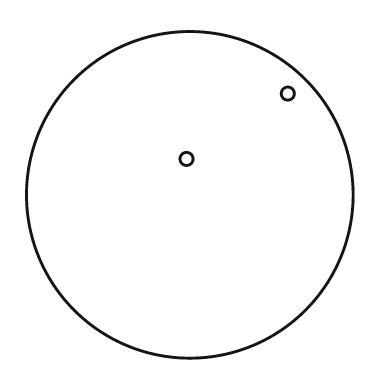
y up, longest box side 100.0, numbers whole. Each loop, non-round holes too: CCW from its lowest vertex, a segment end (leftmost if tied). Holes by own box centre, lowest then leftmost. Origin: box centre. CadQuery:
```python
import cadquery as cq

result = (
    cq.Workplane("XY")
    .moveTo(0.0, 0.0)
    .circle(50.0)
    .moveTo(-1.0, 11.0)
    .circle(2.0)
    .moveTo(30.0, 31.0)
    .circle(2.0)
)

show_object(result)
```